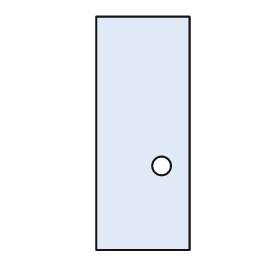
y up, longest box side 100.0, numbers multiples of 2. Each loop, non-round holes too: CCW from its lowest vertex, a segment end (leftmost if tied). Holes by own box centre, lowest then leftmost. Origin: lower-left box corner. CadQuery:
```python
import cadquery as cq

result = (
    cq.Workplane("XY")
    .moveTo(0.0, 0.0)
    .lineTo(40.0, 0.0)
    .lineTo(40.0, 100.0)
    .lineTo(0.0, 100.0)
    .close()
    .moveTo(28.0, 36.0)
    .circle(4.0)
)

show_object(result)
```